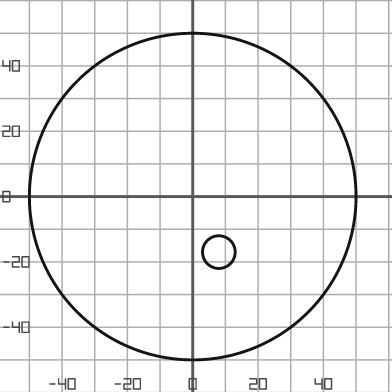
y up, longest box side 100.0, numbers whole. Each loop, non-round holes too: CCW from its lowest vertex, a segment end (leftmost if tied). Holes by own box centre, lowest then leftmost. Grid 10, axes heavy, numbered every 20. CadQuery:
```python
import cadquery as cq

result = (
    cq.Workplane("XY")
    .moveTo(0.0, 0.0)
    .circle(50.0)
    .moveTo(8.0, -17.0)
    .circle(5.0)
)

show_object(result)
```